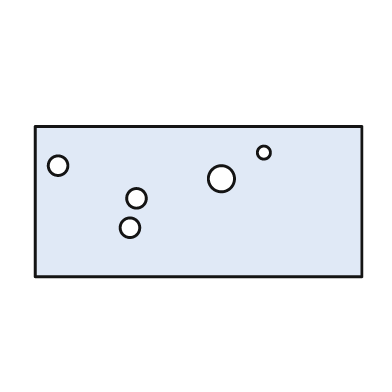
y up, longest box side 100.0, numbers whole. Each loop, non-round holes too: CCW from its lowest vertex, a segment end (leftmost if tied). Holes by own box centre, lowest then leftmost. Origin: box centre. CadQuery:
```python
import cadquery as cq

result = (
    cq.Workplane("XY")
    .moveTo(-50.0, -23.0)
    .lineTo(50.0, -23.0)
    .lineTo(50.0, 23.0)
    .lineTo(-50.0, 23.0)
    .close()
    .moveTo(-21.0, -8.0)
    .circle(3.0)
    .moveTo(-19.0, 1.0)
    .circle(3.0)
    .moveTo(7.0, 7.0)
    .circle(4.0)
    .moveTo(-43.0, 11.0)
    .circle(3.0)
    .moveTo(20.0, 15.0)
    .circle(2.0)
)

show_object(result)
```